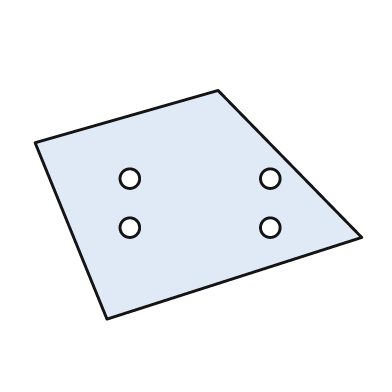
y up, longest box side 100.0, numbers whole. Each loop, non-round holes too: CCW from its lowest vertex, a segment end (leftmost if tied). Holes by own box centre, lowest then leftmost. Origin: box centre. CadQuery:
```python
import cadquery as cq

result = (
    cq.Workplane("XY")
    .moveTo(-28.0, -35.0)
    .lineTo(50.0, -10.0)
    .lineTo(6.0, 35.0)
    .lineTo(-50.0, 19.0)
    .close()
    .moveTo(-21.0, -7.0)
    .circle(3.0)
    .moveTo(22.0, -7.0)
    .circle(3.0)
    .moveTo(-21.0, 8.0)
    .circle(3.0)
    .moveTo(22.0, 8.0)
    .circle(3.0)
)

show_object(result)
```